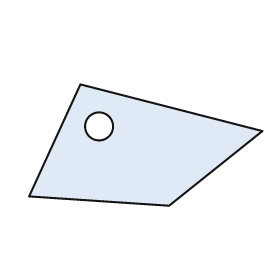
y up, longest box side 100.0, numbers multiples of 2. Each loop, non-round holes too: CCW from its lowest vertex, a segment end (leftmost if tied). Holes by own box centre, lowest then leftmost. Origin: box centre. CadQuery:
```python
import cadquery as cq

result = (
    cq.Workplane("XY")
    .moveTo(10.0, -26.0)
    .lineTo(50.0, 6.0)
    .lineTo(-28.0, 26.0)
    .lineTo(-50.0, -22.0)
    .close()
    .moveTo(-20.0, 8.0)
    .circle(6.0)
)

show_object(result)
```